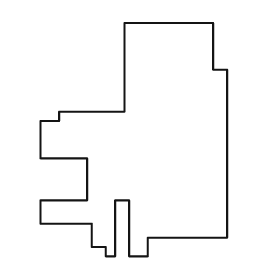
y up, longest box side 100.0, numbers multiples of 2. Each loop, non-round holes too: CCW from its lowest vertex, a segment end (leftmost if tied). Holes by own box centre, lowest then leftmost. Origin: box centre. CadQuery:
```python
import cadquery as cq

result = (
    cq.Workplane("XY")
    .moveTo(-12.0, -50.0)
    .lineTo(-8.0, -50.0)
    .lineTo(-8.0, -26.0)
    .lineTo(-2.0, -26.0)
    .lineTo(-2.0, -50.0)
    .lineTo(6.0, -50.0)
    .lineTo(6.0, -42.0)
    .lineTo(40.0, -42.0)
    .lineTo(40.0, 30.0)
    .lineTo(34.0, 30.0)
    .lineTo(34.0, 50.0)
    .lineTo(-4.0, 50.0)
    .lineTo(-4.0, 12.0)
    .lineTo(-32.0, 12.0)
    .lineTo(-32.0, 8.0)
    .lineTo(-40.0, 8.0)
    .lineTo(-40.0, -8.0)
    .lineTo(-20.0, -8.0)
    .lineTo(-20.0, -26.0)
    .lineTo(-40.0, -26.0)
    .lineTo(-40.0, -36.0)
    .lineTo(-18.0, -36.0)
    .lineTo(-18.0, -46.0)
    .lineTo(-12.0, -46.0)
    .close()
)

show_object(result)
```